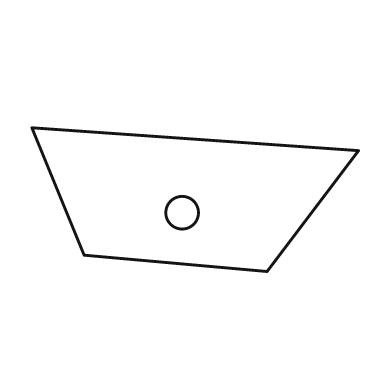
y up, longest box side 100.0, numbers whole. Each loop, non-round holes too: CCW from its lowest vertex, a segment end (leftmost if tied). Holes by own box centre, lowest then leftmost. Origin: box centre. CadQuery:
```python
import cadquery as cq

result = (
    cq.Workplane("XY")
    .moveTo(22.0, -22.0)
    .lineTo(50.0, 15.0)
    .lineTo(-50.0, 22.0)
    .lineTo(-34.0, -17.0)
    .close()
    .moveTo(-4.0, -4.0)
    .circle(5.0)
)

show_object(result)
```